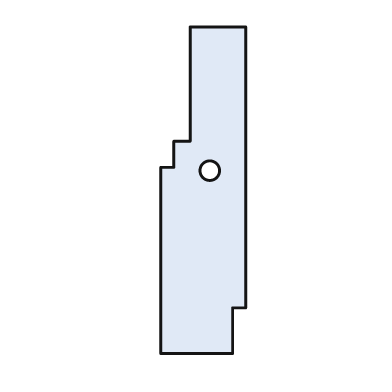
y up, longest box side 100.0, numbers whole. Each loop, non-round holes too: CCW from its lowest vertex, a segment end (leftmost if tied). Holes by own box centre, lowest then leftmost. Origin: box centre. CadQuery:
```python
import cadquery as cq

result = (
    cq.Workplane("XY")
    .moveTo(-13.0, -50.0)
    .lineTo(9.0, -50.0)
    .lineTo(9.0, -36.0)
    .lineTo(13.0, -36.0)
    .lineTo(13.0, 50.0)
    .lineTo(-4.0, 50.0)
    .lineTo(-4.0, 15.0)
    .lineTo(-9.0, 15.0)
    .lineTo(-9.0, 7.0)
    .lineTo(-13.0, 7.0)
    .close()
    .moveTo(2.0, 6.0)
    .circle(3.0)
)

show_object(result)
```